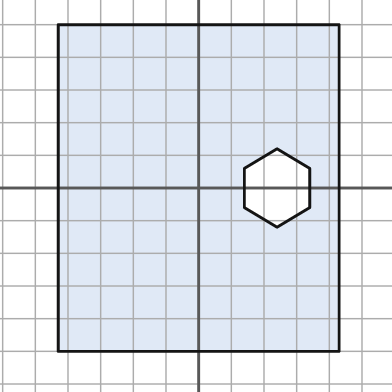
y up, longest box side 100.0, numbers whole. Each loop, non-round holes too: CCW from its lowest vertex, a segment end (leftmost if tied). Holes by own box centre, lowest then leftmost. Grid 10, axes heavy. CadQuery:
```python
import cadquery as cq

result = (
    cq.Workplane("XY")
    .moveTo(-43.0, -50.0)
    .lineTo(43.0, -50.0)
    .lineTo(43.0, 50.0)
    .lineTo(-43.0, 50.0)
    .close()
    .moveTo(24.0, -12.0)
    .lineTo(34.0, -6.0)
    .lineTo(34.0, 6.0)
    .lineTo(24.0, 12.0)
    .lineTo(14.0, 6.0)
    .lineTo(14.0, -6.0)
    .close()
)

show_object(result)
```